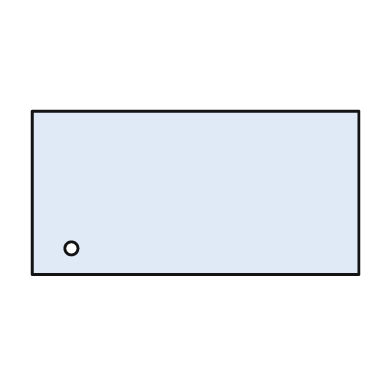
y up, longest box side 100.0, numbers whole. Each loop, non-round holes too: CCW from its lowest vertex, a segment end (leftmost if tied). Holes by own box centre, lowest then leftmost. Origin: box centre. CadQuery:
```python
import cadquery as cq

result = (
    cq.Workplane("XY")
    .moveTo(-50.0, -25.0)
    .lineTo(50.0, -25.0)
    .lineTo(50.0, 25.0)
    .lineTo(-50.0, 25.0)
    .close()
    .moveTo(-38.0, -17.0)
    .circle(2.0)
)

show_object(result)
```